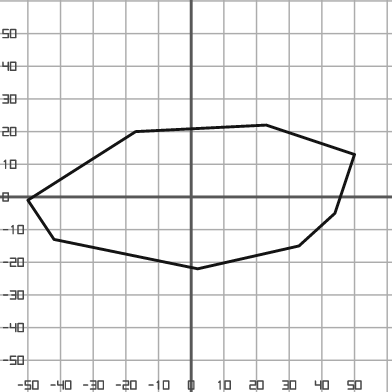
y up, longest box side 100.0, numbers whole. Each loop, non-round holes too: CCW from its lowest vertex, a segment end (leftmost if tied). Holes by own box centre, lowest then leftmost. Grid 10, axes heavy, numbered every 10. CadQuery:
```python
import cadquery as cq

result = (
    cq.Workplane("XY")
    .moveTo(2.0, -22.0)
    .lineTo(33.0, -15.0)
    .lineTo(44.0, -5.0)
    .lineTo(50.0, 13.0)
    .lineTo(23.0, 22.0)
    .lineTo(-17.0, 20.0)
    .lineTo(-50.0, -1.0)
    .lineTo(-42.0, -13.0)
    .close()
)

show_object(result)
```